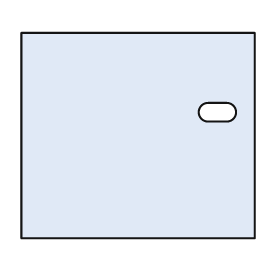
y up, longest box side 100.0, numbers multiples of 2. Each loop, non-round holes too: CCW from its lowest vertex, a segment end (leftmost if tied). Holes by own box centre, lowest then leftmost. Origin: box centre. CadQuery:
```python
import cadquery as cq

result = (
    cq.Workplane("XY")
    .moveTo(-50.0, -44.0)
    .lineTo(50.0, -44.0)
    .lineTo(50.0, 44.0)
    .lineTo(-50.0, 44.0)
    .close()
    .moveTo(30.0, 6.0)
    .lineTo(38.0, 6.0)
    .threePointArc((42.0, 10.0), (38.0, 14.0))
    .lineTo(30.0, 14.0)
    .threePointArc((26.0, 10.0), (30.0, 6.0))
    .close()
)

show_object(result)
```